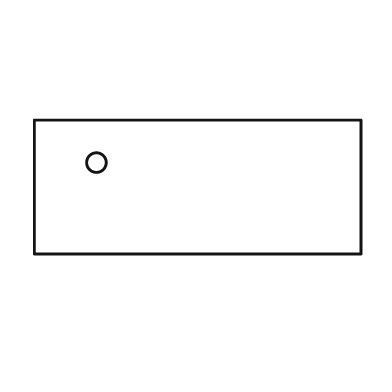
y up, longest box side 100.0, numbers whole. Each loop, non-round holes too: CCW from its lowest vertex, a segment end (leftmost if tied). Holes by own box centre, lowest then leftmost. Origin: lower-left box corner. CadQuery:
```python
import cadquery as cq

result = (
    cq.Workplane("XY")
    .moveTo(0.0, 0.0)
    .lineTo(100.0, 0.0)
    .lineTo(100.0, 41.0)
    .lineTo(0.0, 41.0)
    .close()
    .moveTo(19.0, 28.0)
    .circle(3.0)
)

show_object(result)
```